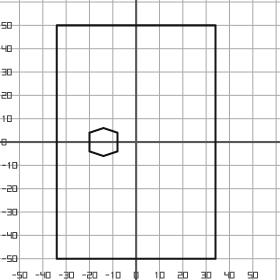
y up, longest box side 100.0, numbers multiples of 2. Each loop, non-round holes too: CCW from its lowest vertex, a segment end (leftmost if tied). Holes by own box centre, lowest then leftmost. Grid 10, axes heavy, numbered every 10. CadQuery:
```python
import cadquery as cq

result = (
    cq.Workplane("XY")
    .moveTo(-34.0, -50.0)
    .lineTo(34.0, -50.0)
    .lineTo(34.0, 50.0)
    .lineTo(-34.0, 50.0)
    .close()
    .moveTo(-14.0, -6.0)
    .lineTo(-8.0, -4.0)
    .lineTo(-8.0, 4.0)
    .lineTo(-14.0, 6.0)
    .lineTo(-20.0, 4.0)
    .lineTo(-20.0, -4.0)
    .close()
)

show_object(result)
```